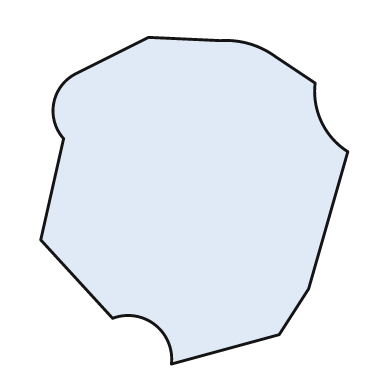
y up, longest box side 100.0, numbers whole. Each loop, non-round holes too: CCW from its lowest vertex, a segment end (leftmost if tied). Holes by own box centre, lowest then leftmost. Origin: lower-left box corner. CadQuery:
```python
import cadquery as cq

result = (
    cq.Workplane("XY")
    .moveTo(40.0, 0.0)
    .lineTo(73.0, 9.0)
    .lineTo(82.0, 23.0)
    .lineTo(94.0, 65.0)
    .threePointArc((86.0, 74.0), (84.0, 86.0))
    .lineTo(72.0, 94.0)
    .threePointArc((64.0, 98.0), (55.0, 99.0))
    .lineTo(33.0, 100.0)
    .lineTo(11.0, 89.0)
    .threePointArc((4.0, 80.0), (7.0, 69.0))
    .lineTo(0.0, 38.0)
    .lineTo(22.0, 14.0)
    .threePointArc((35.0, 12.0), (40.0, 0.0))
    .close()
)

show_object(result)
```